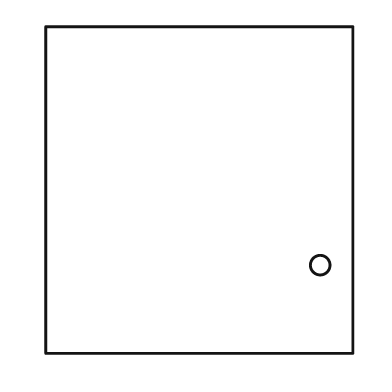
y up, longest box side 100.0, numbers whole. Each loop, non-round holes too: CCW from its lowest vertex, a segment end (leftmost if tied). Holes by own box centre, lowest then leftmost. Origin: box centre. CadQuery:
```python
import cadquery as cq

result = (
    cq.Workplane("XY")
    .moveTo(-47.0, -50.0)
    .lineTo(47.0, -50.0)
    .lineTo(47.0, 50.0)
    .lineTo(-47.0, 50.0)
    .close()
    .moveTo(37.0, -23.0)
    .circle(3.0)
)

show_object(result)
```